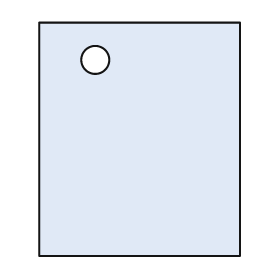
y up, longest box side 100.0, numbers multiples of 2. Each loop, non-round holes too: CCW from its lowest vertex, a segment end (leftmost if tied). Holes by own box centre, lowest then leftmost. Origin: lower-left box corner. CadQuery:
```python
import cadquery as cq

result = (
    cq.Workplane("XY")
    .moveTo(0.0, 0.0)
    .lineTo(86.0, 0.0)
    .lineTo(86.0, 100.0)
    .lineTo(0.0, 100.0)
    .close()
    .moveTo(24.0, 84.0)
    .circle(6.0)
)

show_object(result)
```